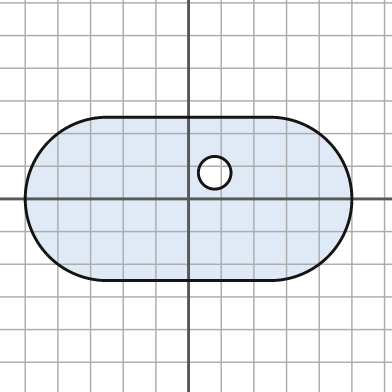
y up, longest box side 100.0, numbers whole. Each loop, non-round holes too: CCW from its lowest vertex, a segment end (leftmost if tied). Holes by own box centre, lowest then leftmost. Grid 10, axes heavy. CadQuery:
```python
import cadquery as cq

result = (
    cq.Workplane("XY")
    .moveTo(-25.0, -25.0)
    .lineTo(25.0, -25.0)
    .threePointArc((50.0, 0.0), (25.0, 25.0))
    .lineTo(-25.0, 25.0)
    .threePointArc((-50.0, 0.0), (-25.0, -25.0))
    .close()
    .moveTo(8.0, 8.0)
    .circle(5.0)
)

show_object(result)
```